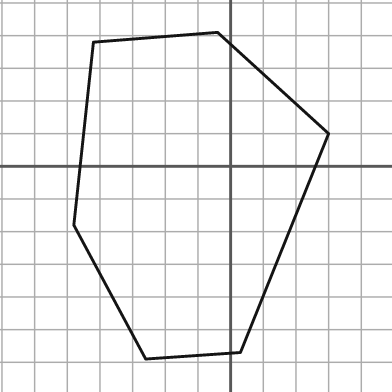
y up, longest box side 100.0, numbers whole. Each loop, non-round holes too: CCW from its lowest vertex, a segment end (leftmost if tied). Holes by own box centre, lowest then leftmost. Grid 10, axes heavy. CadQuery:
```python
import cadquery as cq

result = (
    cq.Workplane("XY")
    .moveTo(-26.0, -59.0)
    .lineTo(3.0, -57.0)
    .lineTo(30.0, 10.0)
    .lineTo(-4.0, 41.0)
    .lineTo(-42.0, 38.0)
    .lineTo(-48.0, -18.0)
    .close()
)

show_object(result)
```